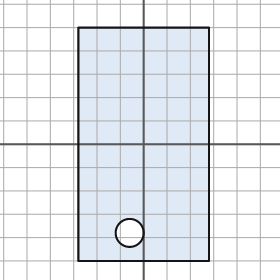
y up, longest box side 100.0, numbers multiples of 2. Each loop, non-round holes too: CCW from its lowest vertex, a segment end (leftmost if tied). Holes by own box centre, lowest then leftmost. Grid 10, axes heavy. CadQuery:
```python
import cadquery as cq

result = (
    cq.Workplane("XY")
    .moveTo(-28.0, -50.0)
    .lineTo(28.0, -50.0)
    .lineTo(28.0, 50.0)
    .lineTo(-28.0, 50.0)
    .close()
    .moveTo(-6.0, -38.0)
    .circle(6.0)
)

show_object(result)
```